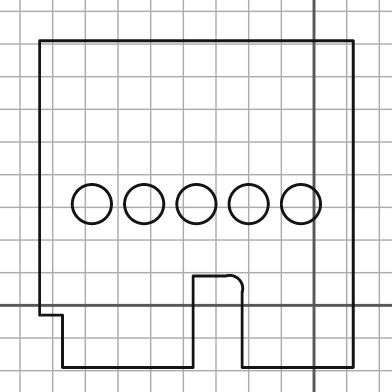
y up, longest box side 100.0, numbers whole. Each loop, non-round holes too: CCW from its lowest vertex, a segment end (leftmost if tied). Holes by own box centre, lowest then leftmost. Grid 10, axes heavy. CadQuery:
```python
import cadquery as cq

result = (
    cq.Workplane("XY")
    .moveTo(-77.0, -19.0)
    .lineTo(-37.0, -19.0)
    .lineTo(-37.0, 9.0)
    .lineTo(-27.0, 9.0)
    .threePointArc((-23.0, 8.0), (-22.0, 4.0))
    .lineTo(-22.0, -19.0)
    .lineTo(12.0, -19.0)
    .lineTo(12.0, 81.0)
    .lineTo(-84.0, 81.0)
    .lineTo(-84.0, -3.0)
    .lineTo(-77.0, -3.0)
    .close()
    .moveTo(-68.0, 31.0)
    .circle(6.0)
    .moveTo(-52.0, 31.0)
    .circle(6.0)
    .moveTo(-36.0, 31.0)
    .circle(6.0)
    .moveTo(-20.0, 31.0)
    .circle(6.0)
    .moveTo(-4.0, 31.0)
    .circle(6.0)
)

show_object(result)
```